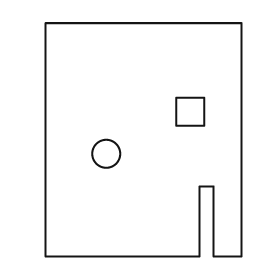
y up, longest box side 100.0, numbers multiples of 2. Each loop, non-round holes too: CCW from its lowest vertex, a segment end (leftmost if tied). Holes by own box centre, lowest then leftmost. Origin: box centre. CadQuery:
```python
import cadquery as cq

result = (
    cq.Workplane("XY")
    .moveTo(-42.0, -50.0)
    .lineTo(24.0, -50.0)
    .lineTo(24.0, -20.0)
    .lineTo(30.0, -20.0)
    .lineTo(30.0, -50.0)
    .lineTo(42.0, -50.0)
    .lineTo(42.0, 50.0)
    .lineTo(-42.0, 50.0)
    .close()
    .moveTo(-16.0, -6.0)
    .circle(6.0)
    .moveTo(14.0, 6.0)
    .lineTo(26.0, 6.0)
    .lineTo(26.0, 18.0)
    .lineTo(14.0, 18.0)
    .close()
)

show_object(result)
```